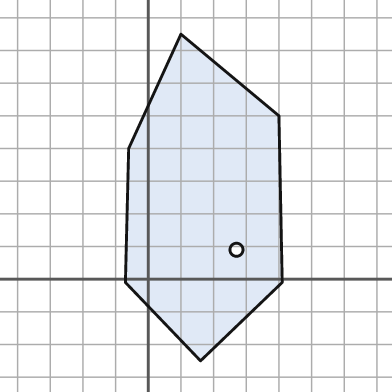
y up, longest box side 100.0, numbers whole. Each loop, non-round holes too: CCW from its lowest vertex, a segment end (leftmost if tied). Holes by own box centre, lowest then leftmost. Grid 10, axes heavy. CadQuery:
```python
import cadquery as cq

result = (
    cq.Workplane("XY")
    .moveTo(16.0, -25.0)
    .lineTo(41.0, -1.0)
    .lineTo(40.0, 50.0)
    .lineTo(10.0, 75.0)
    .lineTo(-6.0, 40.0)
    .lineTo(-7.0, -1.0)
    .close()
    .moveTo(27.0, 9.0)
    .circle(2.0)
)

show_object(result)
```